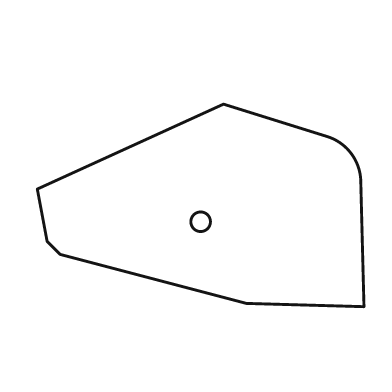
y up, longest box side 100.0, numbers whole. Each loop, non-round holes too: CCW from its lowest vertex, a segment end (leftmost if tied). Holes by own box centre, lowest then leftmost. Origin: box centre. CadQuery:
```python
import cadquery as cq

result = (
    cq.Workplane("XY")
    .moveTo(50.0, -31.0)
    .lineTo(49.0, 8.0)
    .threePointArc((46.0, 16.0), (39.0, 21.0))
    .lineTo(7.0, 31.0)
    .lineTo(-50.0, 5.0)
    .lineTo(-47.0, -11.0)
    .lineTo(-43.0, -15.0)
    .lineTo(14.0, -30.0)
    .close()
    .moveTo(0.0, -5.0)
    .circle(3.0)
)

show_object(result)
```